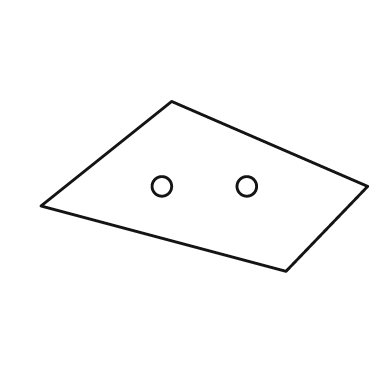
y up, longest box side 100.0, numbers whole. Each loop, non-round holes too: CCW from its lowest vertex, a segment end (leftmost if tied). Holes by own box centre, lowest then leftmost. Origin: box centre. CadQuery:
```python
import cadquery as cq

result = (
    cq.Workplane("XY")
    .moveTo(25.0, -26.0)
    .lineTo(50.0, 0.0)
    .lineTo(-10.0, 26.0)
    .lineTo(-50.0, -6.0)
    .close()
    .moveTo(-13.0, 0.0)
    .circle(3.0)
    .moveTo(13.0, 0.0)
    .circle(3.0)
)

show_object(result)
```